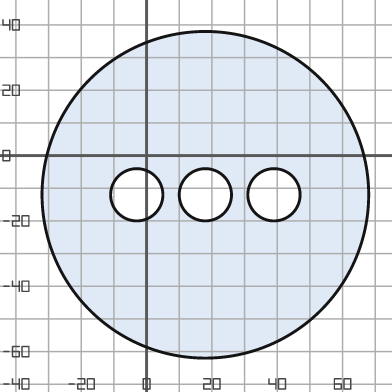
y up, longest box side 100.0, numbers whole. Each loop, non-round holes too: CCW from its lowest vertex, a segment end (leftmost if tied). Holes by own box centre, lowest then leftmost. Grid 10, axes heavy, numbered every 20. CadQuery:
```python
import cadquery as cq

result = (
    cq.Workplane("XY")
    .moveTo(18.0, -12.0)
    .circle(50.0)
    .moveTo(-3.0, -12.0)
    .circle(8.0)
    .moveTo(18.0, -12.0)
    .circle(8.0)
    .moveTo(39.0, -12.0)
    .circle(8.0)
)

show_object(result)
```